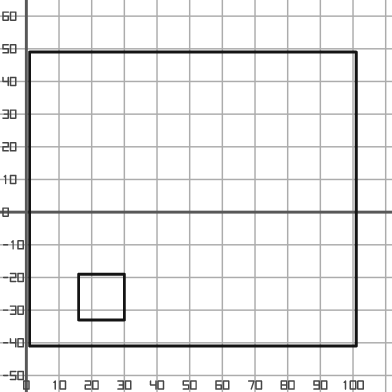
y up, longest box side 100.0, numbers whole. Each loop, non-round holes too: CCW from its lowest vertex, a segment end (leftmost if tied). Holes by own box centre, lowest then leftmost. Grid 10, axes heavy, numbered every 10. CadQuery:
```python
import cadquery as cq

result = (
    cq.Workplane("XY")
    .moveTo(1.0, -41.0)
    .lineTo(101.0, -41.0)
    .lineTo(101.0, 49.0)
    .lineTo(1.0, 49.0)
    .close()
    .moveTo(16.0, -33.0)
    .lineTo(30.0, -33.0)
    .lineTo(30.0, -19.0)
    .lineTo(16.0, -19.0)
    .close()
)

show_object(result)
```